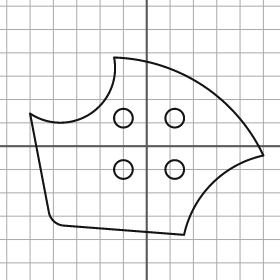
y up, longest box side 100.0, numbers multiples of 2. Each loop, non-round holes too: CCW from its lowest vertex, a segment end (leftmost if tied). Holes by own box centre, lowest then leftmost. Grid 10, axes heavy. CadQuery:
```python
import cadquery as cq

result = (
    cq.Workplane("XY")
    .moveTo(16.0, -38.0)
    .threePointArc((28.0, -16.0), (50.0, -4.0))
    .threePointArc((24.0, 26.0), (-14.0, 38.0))
    .threePointArc((-24.0, 14.0), (-50.0, 14.0))
    .lineTo(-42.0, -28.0)
    .threePointArc((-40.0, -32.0), (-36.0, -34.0))
    .close()
    .moveTo(-10.0, -10.0)
    .circle(4.0)
    .moveTo(12.0, -10.0)
    .circle(4.0)
    .moveTo(-10.0, 12.0)
    .circle(4.0)
    .moveTo(12.0, 12.0)
    .circle(4.0)
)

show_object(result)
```